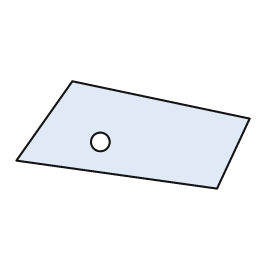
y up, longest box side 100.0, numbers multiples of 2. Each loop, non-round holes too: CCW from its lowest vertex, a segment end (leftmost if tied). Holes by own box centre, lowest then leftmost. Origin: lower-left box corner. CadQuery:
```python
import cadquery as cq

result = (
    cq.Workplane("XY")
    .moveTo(86.0, 0.0)
    .lineTo(100.0, 30.0)
    .lineTo(24.0, 46.0)
    .lineTo(0.0, 12.0)
    .close()
    .moveTo(36.0, 20.0)
    .circle(4.0)
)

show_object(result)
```